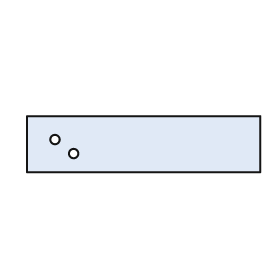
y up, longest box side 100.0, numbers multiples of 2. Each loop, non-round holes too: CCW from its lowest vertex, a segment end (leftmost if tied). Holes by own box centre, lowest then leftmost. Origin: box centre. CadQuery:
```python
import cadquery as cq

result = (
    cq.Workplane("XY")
    .moveTo(-50.0, -12.0)
    .lineTo(50.0, -12.0)
    .lineTo(50.0, 12.0)
    .lineTo(-50.0, 12.0)
    .close()
    .moveTo(-30.0, -4.0)
    .circle(2.0)
    .moveTo(-38.0, 2.0)
    .circle(2.0)
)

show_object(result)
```